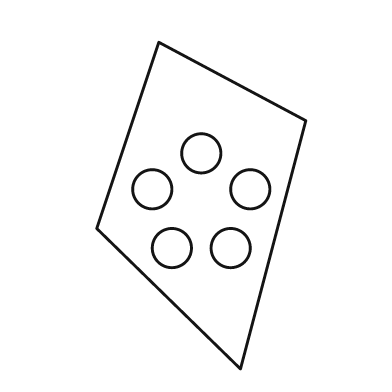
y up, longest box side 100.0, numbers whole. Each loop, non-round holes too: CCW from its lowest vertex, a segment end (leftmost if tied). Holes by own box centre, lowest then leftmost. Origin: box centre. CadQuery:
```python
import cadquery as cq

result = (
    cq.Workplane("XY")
    .moveTo(12.0, -50.0)
    .lineTo(32.0, 26.0)
    .lineTo(-13.0, 50.0)
    .lineTo(-32.0, -7.0)
    .close()
    .moveTo(-9.0, -13.0)
    .circle(6.0)
    .moveTo(9.0, -13.0)
    .circle(6.0)
    .moveTo(-15.0, 5.0)
    .circle(6.0)
    .moveTo(15.0, 5.0)
    .circle(6.0)
    .moveTo(0.0, 16.0)
    .circle(6.0)
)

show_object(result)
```